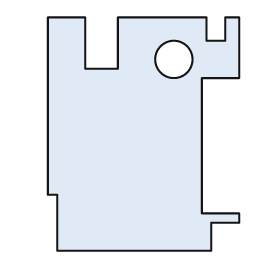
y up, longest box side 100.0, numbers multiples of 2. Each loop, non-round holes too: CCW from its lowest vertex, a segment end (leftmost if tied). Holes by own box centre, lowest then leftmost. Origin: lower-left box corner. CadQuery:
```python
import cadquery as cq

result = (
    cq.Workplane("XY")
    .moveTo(4.0, 0.0)
    .lineTo(70.0, 0.0)
    .lineTo(70.0, 12.0)
    .lineTo(82.0, 12.0)
    .lineTo(82.0, 16.0)
    .lineTo(66.0, 16.0)
    .lineTo(66.0, 74.0)
    .lineTo(82.0, 74.0)
    .lineTo(82.0, 100.0)
    .lineTo(76.0, 100.0)
    .lineTo(76.0, 90.0)
    .lineTo(68.0, 90.0)
    .lineTo(68.0, 100.0)
    .lineTo(30.0, 100.0)
    .lineTo(30.0, 78.0)
    .lineTo(16.0, 78.0)
    .lineTo(16.0, 100.0)
    .lineTo(0.0, 100.0)
    .lineTo(0.0, 24.0)
    .lineTo(4.0, 24.0)
    .close()
    .moveTo(54.0, 82.0)
    .circle(8.0)
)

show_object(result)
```